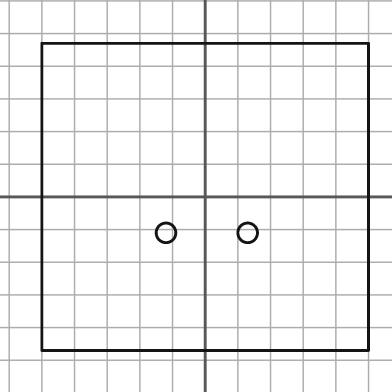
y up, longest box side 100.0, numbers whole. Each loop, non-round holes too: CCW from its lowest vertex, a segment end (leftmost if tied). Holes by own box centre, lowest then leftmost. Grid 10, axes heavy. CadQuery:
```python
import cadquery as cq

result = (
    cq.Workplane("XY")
    .moveTo(-50.0, -47.0)
    .lineTo(50.0, -47.0)
    .lineTo(50.0, 47.0)
    .lineTo(-50.0, 47.0)
    .close()
    .moveTo(-12.0, -11.0)
    .circle(3.0)
    .moveTo(13.0, -11.0)
    .circle(3.0)
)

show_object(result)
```